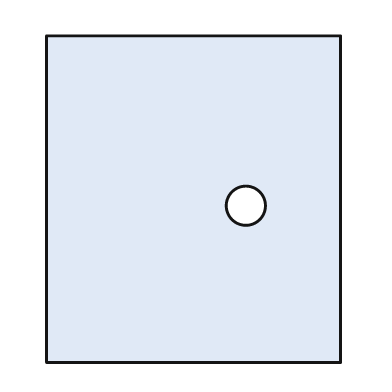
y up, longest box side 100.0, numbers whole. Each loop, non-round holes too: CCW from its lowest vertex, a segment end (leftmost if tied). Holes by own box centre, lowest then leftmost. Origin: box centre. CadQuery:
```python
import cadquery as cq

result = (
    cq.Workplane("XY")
    .moveTo(-45.0, -50.0)
    .lineTo(45.0, -50.0)
    .lineTo(45.0, 50.0)
    .lineTo(-45.0, 50.0)
    .close()
    .moveTo(16.0, -2.0)
    .circle(6.0)
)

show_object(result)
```